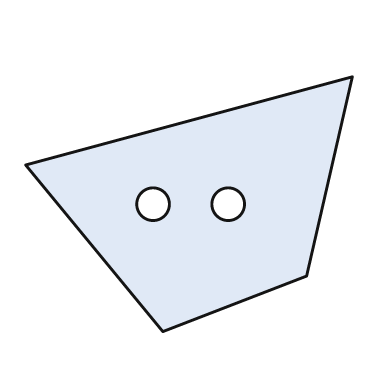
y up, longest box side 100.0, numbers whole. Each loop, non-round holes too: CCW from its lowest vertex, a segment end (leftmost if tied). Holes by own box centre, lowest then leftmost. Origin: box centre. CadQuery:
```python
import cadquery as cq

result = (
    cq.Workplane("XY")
    .moveTo(-8.0, -39.0)
    .lineTo(36.0, -22.0)
    .lineTo(50.0, 39.0)
    .lineTo(-50.0, 12.0)
    .close()
    .moveTo(-11.0, 0.0)
    .circle(5.0)
    .moveTo(12.0, 0.0)
    .circle(5.0)
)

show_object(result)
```